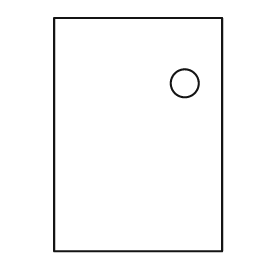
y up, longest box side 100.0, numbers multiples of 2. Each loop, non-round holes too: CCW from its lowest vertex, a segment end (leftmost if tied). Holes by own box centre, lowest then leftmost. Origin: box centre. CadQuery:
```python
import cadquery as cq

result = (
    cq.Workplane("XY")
    .moveTo(-36.0, -50.0)
    .lineTo(36.0, -50.0)
    .lineTo(36.0, 50.0)
    .lineTo(-36.0, 50.0)
    .close()
    .moveTo(20.0, 22.0)
    .circle(6.0)
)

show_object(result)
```